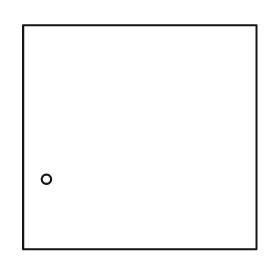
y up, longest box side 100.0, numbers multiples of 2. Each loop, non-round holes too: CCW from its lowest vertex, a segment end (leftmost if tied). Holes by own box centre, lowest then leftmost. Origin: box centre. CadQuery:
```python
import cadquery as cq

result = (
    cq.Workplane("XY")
    .moveTo(-50.0, -48.0)
    .lineTo(50.0, -48.0)
    .lineTo(50.0, 48.0)
    .lineTo(-50.0, 48.0)
    .close()
    .moveTo(-40.0, -18.0)
    .circle(2.0)
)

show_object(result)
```